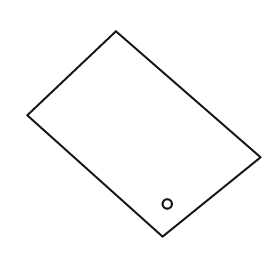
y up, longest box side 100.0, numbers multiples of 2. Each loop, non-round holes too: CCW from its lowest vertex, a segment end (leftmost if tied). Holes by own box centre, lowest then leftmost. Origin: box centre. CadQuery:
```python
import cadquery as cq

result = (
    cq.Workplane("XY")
    .moveTo(8.0, -44.0)
    .lineTo(50.0, -10.0)
    .lineTo(-12.0, 44.0)
    .lineTo(-50.0, 8.0)
    .close()
    .moveTo(10.0, -30.0)
    .circle(2.0)
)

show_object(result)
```